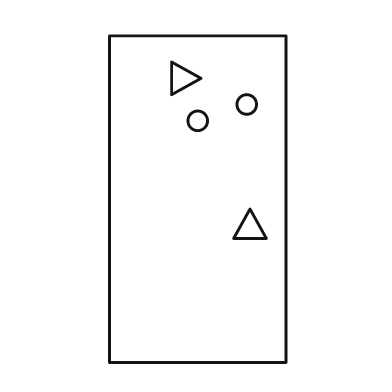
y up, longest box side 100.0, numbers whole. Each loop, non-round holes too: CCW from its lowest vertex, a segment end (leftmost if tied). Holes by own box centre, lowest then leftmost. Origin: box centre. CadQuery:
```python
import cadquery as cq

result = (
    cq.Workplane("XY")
    .moveTo(-27.0, -50.0)
    .lineTo(27.0, -50.0)
    .lineTo(27.0, 50.0)
    .lineTo(-27.0, 50.0)
    .close()
    .moveTo(11.0, -12.0)
    .lineTo(21.0, -12.0)
    .lineTo(16.0, -3.0)
    .close()
    .moveTo(0.0, 24.0)
    .circle(3.0)
    .moveTo(15.0, 29.0)
    .circle(3.0)
    .moveTo(-8.0, 32.0)
    .lineTo(1.0, 37.0)
    .lineTo(-8.0, 42.0)
    .close()
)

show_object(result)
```